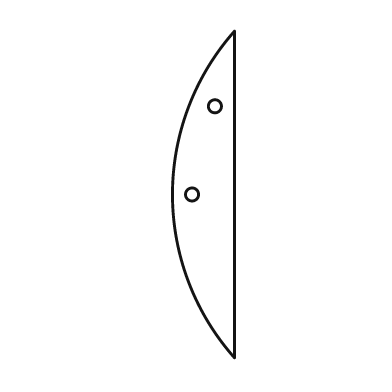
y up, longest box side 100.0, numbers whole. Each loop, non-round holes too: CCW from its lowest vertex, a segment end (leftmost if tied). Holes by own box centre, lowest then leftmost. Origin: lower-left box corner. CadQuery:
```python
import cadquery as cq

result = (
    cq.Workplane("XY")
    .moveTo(19.0, 0.0)
    .lineTo(19.0, 100.0)
    .threePointArc((0.0, 50.0), (19.0, 0.0))
    .close()
    .moveTo(6.0, 50.0)
    .circle(2.0)
    .moveTo(13.0, 77.0)
    .circle(2.0)
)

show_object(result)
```